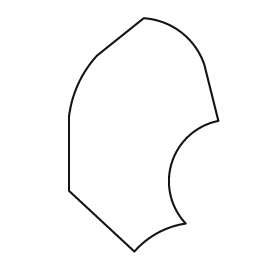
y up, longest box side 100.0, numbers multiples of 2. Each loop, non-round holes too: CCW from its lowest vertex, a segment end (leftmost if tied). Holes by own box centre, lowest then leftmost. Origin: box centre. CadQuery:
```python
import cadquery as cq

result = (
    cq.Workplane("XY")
    .moveTo(-4.0, -50.0)
    .threePointArc((6.0, -42.0), (18.0, -38.0))
    .threePointArc((12.0, -12.0), (32.0, 6.0))
    .lineTo(26.0, 30.0)
    .threePointArc((16.0, 44.0), (0.0, 50.0))
    .lineTo(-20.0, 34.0)
    .threePointArc((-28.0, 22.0), (-32.0, 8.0))
    .lineTo(-32.0, -24.0)
    .close()
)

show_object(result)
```